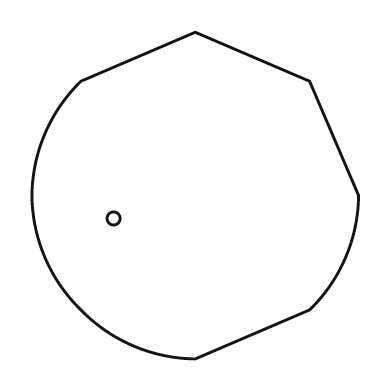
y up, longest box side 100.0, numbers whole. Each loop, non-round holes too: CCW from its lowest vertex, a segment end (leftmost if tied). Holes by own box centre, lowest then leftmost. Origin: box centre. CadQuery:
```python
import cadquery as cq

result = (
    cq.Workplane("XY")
    .moveTo(0.0, -50.0)
    .lineTo(35.0, -35.0)
    .threePointArc((46.0, -19.0), (50.0, 0.0))
    .lineTo(35.0, 35.0)
    .lineTo(0.0, 50.0)
    .lineTo(-35.0, 35.0)
    .threePointArc((-46.0, 19.0), (-50.0, 0.0))
    .threePointArc((-46.0, -19.0), (-35.0, -35.0))
    .threePointArc((-19.0, -46.0), (0.0, -50.0))
    .close()
    .moveTo(-25.0, -7.0)
    .circle(2.0)
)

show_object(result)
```